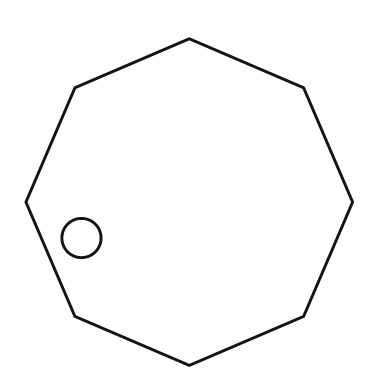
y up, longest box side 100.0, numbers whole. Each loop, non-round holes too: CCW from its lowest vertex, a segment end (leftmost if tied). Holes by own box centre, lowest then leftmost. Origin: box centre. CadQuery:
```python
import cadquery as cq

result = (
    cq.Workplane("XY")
    .moveTo(0.0, -50.0)
    .lineTo(35.0, -35.0)
    .lineTo(50.0, 0.0)
    .lineTo(35.0, 35.0)
    .lineTo(0.0, 50.0)
    .lineTo(-35.0, 35.0)
    .lineTo(-50.0, 0.0)
    .lineTo(-35.0, -35.0)
    .close()
    .moveTo(-33.0, -11.0)
    .circle(6.0)
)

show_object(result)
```